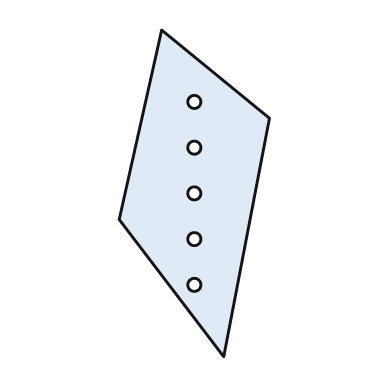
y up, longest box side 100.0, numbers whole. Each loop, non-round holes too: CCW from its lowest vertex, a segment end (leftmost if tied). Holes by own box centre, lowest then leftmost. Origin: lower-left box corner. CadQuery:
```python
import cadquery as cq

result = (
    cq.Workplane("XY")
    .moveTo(32.0, 0.0)
    .lineTo(46.0, 73.0)
    .lineTo(13.0, 100.0)
    .lineTo(0.0, 42.0)
    .close()
    .moveTo(23.0, 22.0)
    .circle(2.0)
    .moveTo(23.0, 36.0)
    .circle(2.0)
    .moveTo(23.0, 50.0)
    .circle(2.0)
    .moveTo(23.0, 64.0)
    .circle(2.0)
    .moveTo(23.0, 78.0)
    .circle(2.0)
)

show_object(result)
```